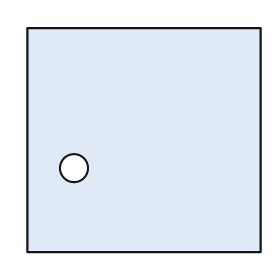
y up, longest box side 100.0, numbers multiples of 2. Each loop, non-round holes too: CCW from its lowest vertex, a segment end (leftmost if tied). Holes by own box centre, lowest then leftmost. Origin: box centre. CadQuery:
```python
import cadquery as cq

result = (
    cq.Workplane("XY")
    .moveTo(-50.0, -48.0)
    .lineTo(50.0, -48.0)
    .lineTo(50.0, 48.0)
    .lineTo(-50.0, 48.0)
    .close()
    .moveTo(-30.0, -12.0)
    .circle(6.0)
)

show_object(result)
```